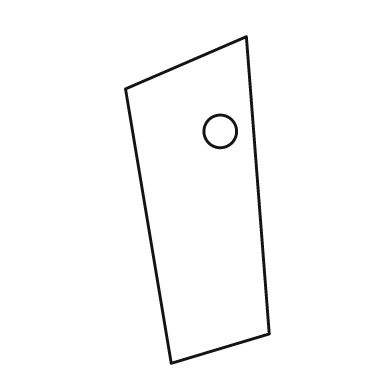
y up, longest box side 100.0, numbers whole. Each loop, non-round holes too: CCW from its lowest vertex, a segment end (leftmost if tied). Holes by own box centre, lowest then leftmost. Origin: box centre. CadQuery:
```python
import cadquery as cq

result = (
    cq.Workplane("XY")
    .moveTo(-8.0, -50.0)
    .lineTo(22.0, -41.0)
    .lineTo(15.0, 50.0)
    .lineTo(-22.0, 34.0)
    .close()
    .moveTo(7.0, 21.0)
    .circle(5.0)
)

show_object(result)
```